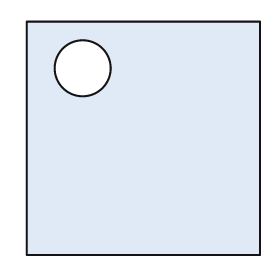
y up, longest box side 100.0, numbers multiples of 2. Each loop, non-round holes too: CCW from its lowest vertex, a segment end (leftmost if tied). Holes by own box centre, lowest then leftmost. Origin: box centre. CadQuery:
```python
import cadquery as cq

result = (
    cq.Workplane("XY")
    .moveTo(-50.0, -50.0)
    .lineTo(50.0, -50.0)
    .lineTo(50.0, 50.0)
    .lineTo(-50.0, 50.0)
    .close()
    .moveTo(-26.0, 30.0)
    .circle(12.0)
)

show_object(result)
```